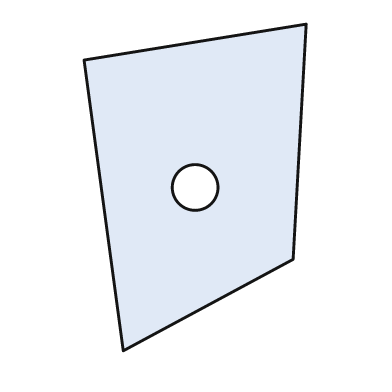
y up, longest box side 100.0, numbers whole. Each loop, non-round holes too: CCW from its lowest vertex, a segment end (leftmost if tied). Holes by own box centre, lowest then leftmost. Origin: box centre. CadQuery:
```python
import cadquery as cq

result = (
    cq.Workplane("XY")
    .moveTo(-22.0, -50.0)
    .lineTo(30.0, -22.0)
    .lineTo(34.0, 50.0)
    .lineTo(-34.0, 39.0)
    .close()
    .moveTo(0.0, 0.0)
    .circle(7.0)
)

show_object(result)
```